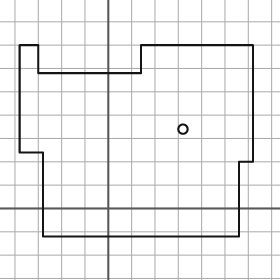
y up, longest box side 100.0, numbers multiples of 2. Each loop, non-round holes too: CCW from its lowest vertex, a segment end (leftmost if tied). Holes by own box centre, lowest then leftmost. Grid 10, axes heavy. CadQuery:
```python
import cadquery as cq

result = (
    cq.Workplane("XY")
    .moveTo(-28.0, -12.0)
    .lineTo(56.0, -12.0)
    .lineTo(56.0, 20.0)
    .lineTo(62.0, 20.0)
    .lineTo(62.0, 70.0)
    .lineTo(14.0, 70.0)
    .lineTo(14.0, 58.0)
    .lineTo(-30.0, 58.0)
    .lineTo(-30.0, 70.0)
    .lineTo(-38.0, 70.0)
    .lineTo(-38.0, 24.0)
    .lineTo(-28.0, 24.0)
    .close()
    .moveTo(32.0, 34.0)
    .circle(2.0)
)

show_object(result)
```